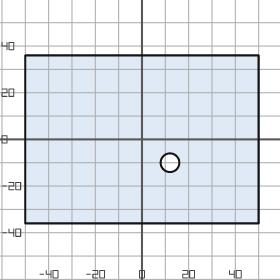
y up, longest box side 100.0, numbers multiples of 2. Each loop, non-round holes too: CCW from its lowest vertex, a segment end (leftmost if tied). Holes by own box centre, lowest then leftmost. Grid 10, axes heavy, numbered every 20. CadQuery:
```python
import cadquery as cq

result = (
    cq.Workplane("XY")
    .moveTo(-50.0, -36.0)
    .lineTo(50.0, -36.0)
    .lineTo(50.0, 36.0)
    .lineTo(-50.0, 36.0)
    .close()
    .moveTo(12.0, -10.0)
    .circle(4.0)
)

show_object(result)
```